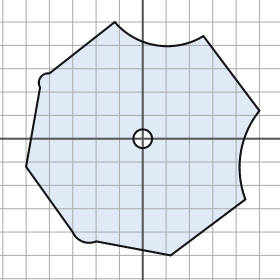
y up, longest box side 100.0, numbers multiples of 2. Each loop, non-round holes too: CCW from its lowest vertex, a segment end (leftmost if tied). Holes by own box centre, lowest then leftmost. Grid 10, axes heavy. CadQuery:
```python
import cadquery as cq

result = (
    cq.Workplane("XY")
    .moveTo(12.0, -50.0)
    .lineTo(44.0, -26.0)
    .threePointArc((42.0, -6.0), (50.0, 12.0))
    .lineTo(26.0, 44.0)
    .threePointArc((6.0, 40.0), (-12.0, 50.0))
    .lineTo(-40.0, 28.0)
    .threePointArc((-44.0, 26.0), (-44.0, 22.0))
    .lineTo(-50.0, -12.0)
    .lineTo(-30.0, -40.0)
    .threePointArc((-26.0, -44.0), (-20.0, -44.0))
    .close()
    .moveTo(0.0, 0.0)
    .circle(4.0)
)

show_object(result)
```